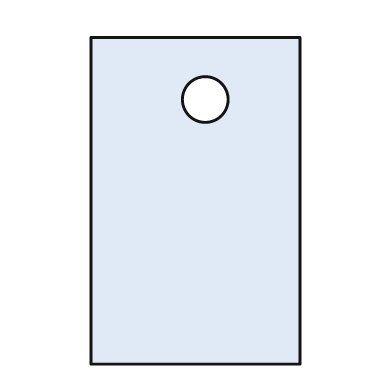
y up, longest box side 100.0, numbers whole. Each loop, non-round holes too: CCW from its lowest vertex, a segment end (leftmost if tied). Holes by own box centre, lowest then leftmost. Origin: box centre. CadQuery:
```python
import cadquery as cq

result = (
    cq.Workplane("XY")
    .moveTo(-32.0, -50.0)
    .lineTo(32.0, -50.0)
    .lineTo(32.0, 50.0)
    .lineTo(-32.0, 50.0)
    .close()
    .moveTo(3.0, 31.0)
    .circle(7.0)
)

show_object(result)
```